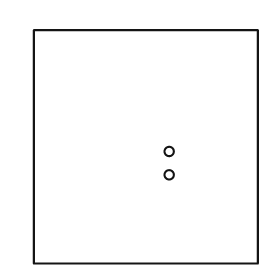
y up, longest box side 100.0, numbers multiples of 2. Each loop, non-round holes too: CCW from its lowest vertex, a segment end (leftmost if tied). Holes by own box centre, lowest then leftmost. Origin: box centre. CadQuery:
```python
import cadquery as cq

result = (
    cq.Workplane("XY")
    .moveTo(-48.0, -50.0)
    .lineTo(48.0, -50.0)
    .lineTo(48.0, 50.0)
    .lineTo(-48.0, 50.0)
    .close()
    .moveTo(10.0, -12.0)
    .circle(2.0)
    .moveTo(10.0, -2.0)
    .circle(2.0)
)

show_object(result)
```